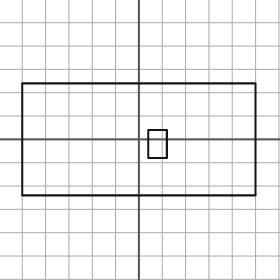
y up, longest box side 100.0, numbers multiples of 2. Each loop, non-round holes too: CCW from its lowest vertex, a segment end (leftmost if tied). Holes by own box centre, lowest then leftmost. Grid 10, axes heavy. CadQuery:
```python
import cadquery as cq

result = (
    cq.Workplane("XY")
    .moveTo(-50.0, -24.0)
    .lineTo(50.0, -24.0)
    .lineTo(50.0, 24.0)
    .lineTo(-50.0, 24.0)
    .close()
    .moveTo(4.0, -8.0)
    .lineTo(12.0, -8.0)
    .lineTo(12.0, 4.0)
    .lineTo(4.0, 4.0)
    .close()
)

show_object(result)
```